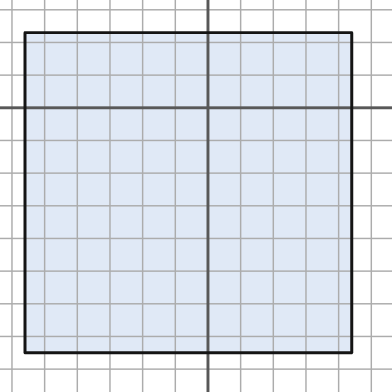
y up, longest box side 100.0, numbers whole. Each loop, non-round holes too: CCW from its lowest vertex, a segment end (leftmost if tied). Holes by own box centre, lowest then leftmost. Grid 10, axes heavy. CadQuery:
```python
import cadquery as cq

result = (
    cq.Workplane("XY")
    .moveTo(-56.0, -75.0)
    .lineTo(44.0, -75.0)
    .lineTo(44.0, 23.0)
    .lineTo(-56.0, 23.0)
    .close()
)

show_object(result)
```